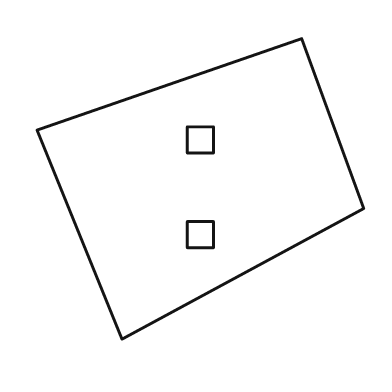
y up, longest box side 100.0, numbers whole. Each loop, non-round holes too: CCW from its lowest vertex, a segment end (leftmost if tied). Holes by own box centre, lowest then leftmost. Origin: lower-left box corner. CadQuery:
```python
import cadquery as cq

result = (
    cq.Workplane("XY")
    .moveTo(26.0, 0.0)
    .lineTo(100.0, 40.0)
    .lineTo(81.0, 92.0)
    .lineTo(0.0, 64.0)
    .close()
    .moveTo(46.0, 28.0)
    .lineTo(54.0, 28.0)
    .lineTo(54.0, 36.0)
    .lineTo(46.0, 36.0)
    .close()
    .moveTo(46.0, 57.0)
    .lineTo(54.0, 57.0)
    .lineTo(54.0, 65.0)
    .lineTo(46.0, 65.0)
    .close()
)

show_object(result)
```